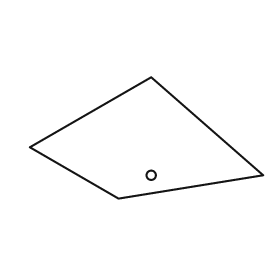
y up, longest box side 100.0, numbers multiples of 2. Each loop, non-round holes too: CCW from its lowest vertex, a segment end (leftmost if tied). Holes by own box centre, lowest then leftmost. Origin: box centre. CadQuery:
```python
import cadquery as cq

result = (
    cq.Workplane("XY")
    .moveTo(-12.0, -26.0)
    .lineTo(50.0, -16.0)
    .lineTo(2.0, 26.0)
    .lineTo(-50.0, -4.0)
    .close()
    .moveTo(2.0, -16.0)
    .circle(2.0)
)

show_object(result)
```